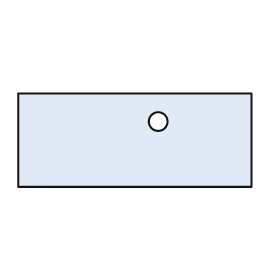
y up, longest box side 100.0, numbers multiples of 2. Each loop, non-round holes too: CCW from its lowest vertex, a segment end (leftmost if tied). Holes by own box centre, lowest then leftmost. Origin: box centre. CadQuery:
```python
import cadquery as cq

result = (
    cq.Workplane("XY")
    .moveTo(-50.0, -20.0)
    .lineTo(50.0, -20.0)
    .lineTo(50.0, 20.0)
    .lineTo(-50.0, 20.0)
    .close()
    .moveTo(10.0, 8.0)
    .circle(4.0)
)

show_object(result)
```